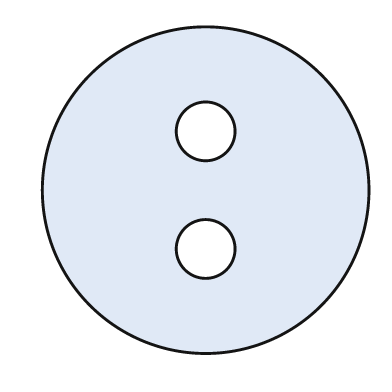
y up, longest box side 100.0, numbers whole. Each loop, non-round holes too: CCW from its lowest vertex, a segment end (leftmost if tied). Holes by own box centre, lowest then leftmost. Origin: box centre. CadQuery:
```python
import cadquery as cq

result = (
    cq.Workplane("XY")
    .moveTo(0.0, 0.0)
    .circle(50.0)
    .moveTo(0.0, -18.0)
    .circle(9.0)
    .moveTo(0.0, 18.0)
    .circle(9.0)
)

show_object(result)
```